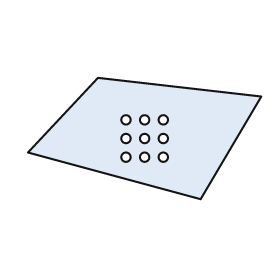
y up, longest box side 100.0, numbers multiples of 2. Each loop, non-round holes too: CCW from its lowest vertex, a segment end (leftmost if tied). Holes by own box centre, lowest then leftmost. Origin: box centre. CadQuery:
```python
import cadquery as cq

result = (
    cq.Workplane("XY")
    .moveTo(24.0, -26.0)
    .lineTo(50.0, 18.0)
    .lineTo(-20.0, 26.0)
    .lineTo(-50.0, -6.0)
    .close()
    .moveTo(-8.0, -8.0)
    .circle(2.0)
    .moveTo(0.0, -8.0)
    .circle(2.0)
    .moveTo(8.0, -8.0)
    .circle(2.0)
    .moveTo(-8.0, 0.0)
    .circle(2.0)
    .moveTo(0.0, 0.0)
    .circle(2.0)
    .moveTo(8.0, 0.0)
    .circle(2.0)
    .moveTo(-8.0, 8.0)
    .circle(2.0)
    .moveTo(0.0, 8.0)
    .circle(2.0)
    .moveTo(8.0, 8.0)
    .circle(2.0)
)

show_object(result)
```